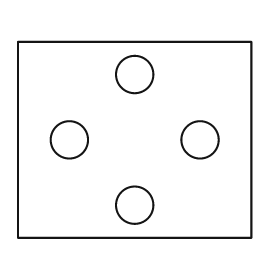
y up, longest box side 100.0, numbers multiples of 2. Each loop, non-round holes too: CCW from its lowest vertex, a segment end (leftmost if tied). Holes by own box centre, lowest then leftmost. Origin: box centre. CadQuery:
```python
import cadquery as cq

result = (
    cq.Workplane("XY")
    .moveTo(-50.0, -42.0)
    .lineTo(50.0, -42.0)
    .lineTo(50.0, 42.0)
    .lineTo(-50.0, 42.0)
    .close()
    .moveTo(0.0, -28.0)
    .circle(8.0)
    .moveTo(-28.0, 0.0)
    .circle(8.0)
    .moveTo(28.0, 0.0)
    .circle(8.0)
    .moveTo(0.0, 28.0)
    .circle(8.0)
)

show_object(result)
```